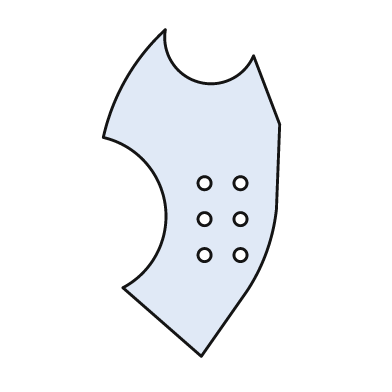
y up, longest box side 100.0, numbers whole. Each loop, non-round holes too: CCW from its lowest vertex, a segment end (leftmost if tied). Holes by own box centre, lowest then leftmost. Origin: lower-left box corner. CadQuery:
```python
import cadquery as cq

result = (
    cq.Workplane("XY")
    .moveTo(30.0, 0.0)
    .lineTo(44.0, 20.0)
    .threePointArc((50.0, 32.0), (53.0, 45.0))
    .lineTo(54.0, 71.0)
    .lineTo(46.0, 92.0)
    .threePointArc((29.0, 84.0), (19.0, 100.0))
    .threePointArc((7.0, 85.0), (0.0, 67.0))
    .threePointArc((19.0, 46.0), (6.0, 21.0))
    .close()
    .moveTo(31.0, 31.0)
    .circle(2.0)
    .moveTo(42.0, 31.0)
    .circle(2.0)
    .moveTo(31.0, 42.0)
    .circle(2.0)
    .moveTo(42.0, 42.0)
    .circle(2.0)
    .moveTo(31.0, 53.0)
    .circle(2.0)
    .moveTo(42.0, 53.0)
    .circle(2.0)
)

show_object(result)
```